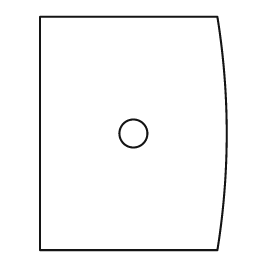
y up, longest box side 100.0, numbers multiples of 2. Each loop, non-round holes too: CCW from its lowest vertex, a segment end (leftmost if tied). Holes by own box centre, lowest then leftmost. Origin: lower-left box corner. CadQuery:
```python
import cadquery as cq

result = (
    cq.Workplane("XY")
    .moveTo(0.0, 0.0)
    .lineTo(76.0, 0.0)
    .threePointArc((80.0, 50.0), (76.0, 100.0))
    .lineTo(0.0, 100.0)
    .close()
    .moveTo(40.0, 50.0)
    .circle(6.0)
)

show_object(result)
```